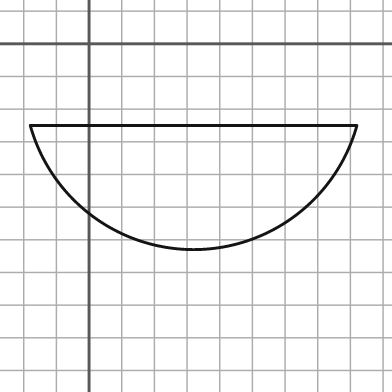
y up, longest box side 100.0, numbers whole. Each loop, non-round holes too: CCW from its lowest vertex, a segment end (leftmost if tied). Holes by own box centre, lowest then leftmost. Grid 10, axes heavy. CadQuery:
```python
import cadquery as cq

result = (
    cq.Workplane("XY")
    .moveTo(-18.0, -25.0)
    .threePointArc((32.0, -63.0), (82.0, -25.0))
    .close()
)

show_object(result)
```